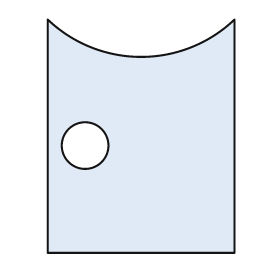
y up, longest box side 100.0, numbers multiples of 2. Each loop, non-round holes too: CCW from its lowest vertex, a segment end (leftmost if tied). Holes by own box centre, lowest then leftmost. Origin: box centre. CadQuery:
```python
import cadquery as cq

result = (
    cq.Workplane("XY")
    .moveTo(-40.0, -50.0)
    .lineTo(40.0, -50.0)
    .lineTo(40.0, 50.0)
    .threePointArc((0.0, 34.0), (-40.0, 50.0))
    .close()
    .moveTo(-24.0, -4.0)
    .circle(10.0)
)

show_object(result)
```